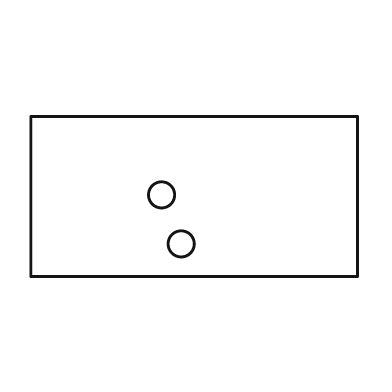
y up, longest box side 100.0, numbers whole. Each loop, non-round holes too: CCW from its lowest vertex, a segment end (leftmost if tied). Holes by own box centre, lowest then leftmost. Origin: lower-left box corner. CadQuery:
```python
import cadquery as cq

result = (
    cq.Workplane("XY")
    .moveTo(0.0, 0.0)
    .lineTo(100.0, 0.0)
    .lineTo(100.0, 49.0)
    .lineTo(0.0, 49.0)
    .close()
    .moveTo(46.0, 10.0)
    .circle(4.0)
    .moveTo(40.0, 25.0)
    .circle(4.0)
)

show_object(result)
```